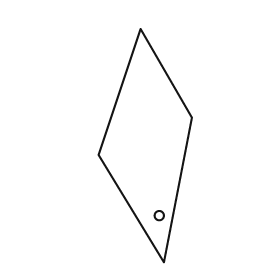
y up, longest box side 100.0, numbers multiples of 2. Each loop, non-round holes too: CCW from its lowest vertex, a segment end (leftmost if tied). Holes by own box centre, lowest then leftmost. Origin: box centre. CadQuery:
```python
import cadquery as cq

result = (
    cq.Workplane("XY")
    .moveTo(8.0, -50.0)
    .lineTo(20.0, 12.0)
    .lineTo(-2.0, 50.0)
    .lineTo(-20.0, -4.0)
    .close()
    .moveTo(6.0, -30.0)
    .circle(2.0)
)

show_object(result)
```